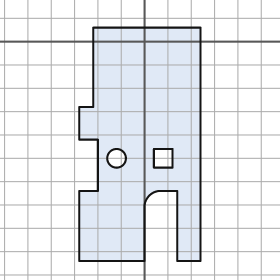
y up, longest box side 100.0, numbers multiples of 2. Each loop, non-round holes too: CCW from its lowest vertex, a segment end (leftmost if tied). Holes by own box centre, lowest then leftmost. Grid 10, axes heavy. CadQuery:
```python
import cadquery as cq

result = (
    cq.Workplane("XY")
    .moveTo(-28.0, -94.0)
    .lineTo(0.0, -94.0)
    .lineTo(0.0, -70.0)
    .threePointArc((2.0, -66.0), (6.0, -64.0))
    .lineTo(14.0, -64.0)
    .lineTo(14.0, -94.0)
    .lineTo(24.0, -94.0)
    .lineTo(24.0, 6.0)
    .lineTo(-22.0, 6.0)
    .lineTo(-22.0, -28.0)
    .lineTo(-28.0, -28.0)
    .lineTo(-28.0, -42.0)
    .lineTo(-20.0, -42.0)
    .lineTo(-20.0, -64.0)
    .lineTo(-28.0, -64.0)
    .close()
    .moveTo(-12.0, -50.0)
    .circle(4.0)
    .moveTo(4.0, -54.0)
    .lineTo(12.0, -54.0)
    .lineTo(12.0, -46.0)
    .lineTo(4.0, -46.0)
    .close()
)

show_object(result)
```